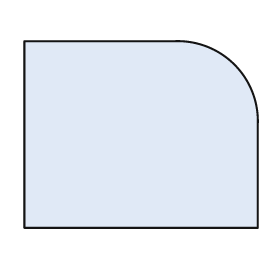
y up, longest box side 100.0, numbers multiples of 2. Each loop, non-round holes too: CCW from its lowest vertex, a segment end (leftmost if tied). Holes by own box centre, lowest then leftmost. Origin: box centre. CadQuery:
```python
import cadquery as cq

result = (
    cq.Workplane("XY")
    .moveTo(-50.0, -40.0)
    .lineTo(50.0, -40.0)
    .lineTo(50.0, 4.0)
    .threePointArc((40.0, 30.0), (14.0, 40.0))
    .lineTo(-50.0, 40.0)
    .close()
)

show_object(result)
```